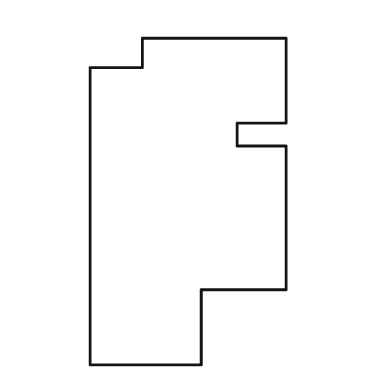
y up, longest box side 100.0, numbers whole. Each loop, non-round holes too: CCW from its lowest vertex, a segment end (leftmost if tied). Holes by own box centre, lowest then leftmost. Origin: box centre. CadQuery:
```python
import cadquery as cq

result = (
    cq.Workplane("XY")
    .moveTo(-30.0, -50.0)
    .lineTo(4.0, -50.0)
    .lineTo(4.0, -27.0)
    .lineTo(30.0, -27.0)
    .lineTo(30.0, 17.0)
    .lineTo(15.0, 17.0)
    .lineTo(15.0, 24.0)
    .lineTo(30.0, 24.0)
    .lineTo(30.0, 50.0)
    .lineTo(-14.0, 50.0)
    .lineTo(-14.0, 41.0)
    .lineTo(-30.0, 41.0)
    .close()
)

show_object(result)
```